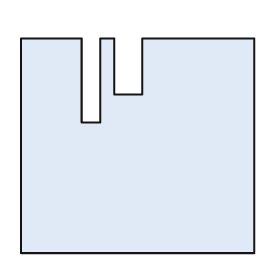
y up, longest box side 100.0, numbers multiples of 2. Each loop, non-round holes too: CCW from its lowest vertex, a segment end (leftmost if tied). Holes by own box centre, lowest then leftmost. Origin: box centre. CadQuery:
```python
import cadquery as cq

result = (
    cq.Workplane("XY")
    .moveTo(-50.0, -46.0)
    .lineTo(50.0, -46.0)
    .lineTo(50.0, 46.0)
    .lineTo(2.0, 46.0)
    .lineTo(2.0, 22.0)
    .lineTo(-10.0, 22.0)
    .lineTo(-10.0, 46.0)
    .lineTo(-16.0, 46.0)
    .lineTo(-16.0, 10.0)
    .lineTo(-24.0, 10.0)
    .lineTo(-24.0, 46.0)
    .lineTo(-50.0, 46.0)
    .close()
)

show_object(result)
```